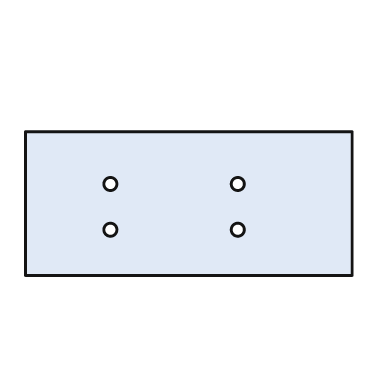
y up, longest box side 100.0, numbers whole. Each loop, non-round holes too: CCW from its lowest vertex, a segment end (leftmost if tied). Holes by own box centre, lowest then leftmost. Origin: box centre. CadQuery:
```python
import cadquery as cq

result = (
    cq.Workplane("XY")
    .moveTo(-50.0, -22.0)
    .lineTo(50.0, -22.0)
    .lineTo(50.0, 22.0)
    .lineTo(-50.0, 22.0)
    .close()
    .moveTo(-24.0, -8.0)
    .circle(2.0)
    .moveTo(15.0, -8.0)
    .circle(2.0)
    .moveTo(-24.0, 6.0)
    .circle(2.0)
    .moveTo(15.0, 6.0)
    .circle(2.0)
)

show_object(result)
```